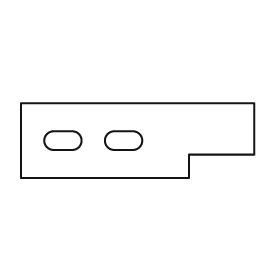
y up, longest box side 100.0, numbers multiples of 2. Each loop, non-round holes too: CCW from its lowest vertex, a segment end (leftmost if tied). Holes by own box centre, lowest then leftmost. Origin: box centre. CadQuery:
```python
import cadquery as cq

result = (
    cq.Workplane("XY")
    .moveTo(-50.0, -16.0)
    .lineTo(22.0, -16.0)
    .lineTo(22.0, -6.0)
    .lineTo(50.0, -6.0)
    .lineTo(50.0, 16.0)
    .lineTo(-50.0, 16.0)
    .close()
    .moveTo(-36.0, -4.0)
    .lineTo(-28.0, -4.0)
    .threePointArc((-24.0, 0.0), (-28.0, 4.0))
    .lineTo(-36.0, 4.0)
    .threePointArc((-40.0, 0.0), (-36.0, -4.0))
    .close()
    .moveTo(-10.0, -4.0)
    .lineTo(-2.0, -4.0)
    .threePointArc((2.0, 0.0), (-2.0, 4.0))
    .lineTo(-10.0, 4.0)
    .threePointArc((-14.0, 0.0), (-10.0, -4.0))
    .close()
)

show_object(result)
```